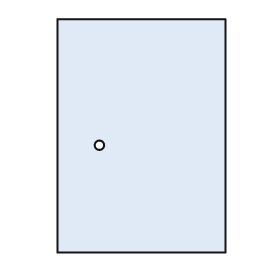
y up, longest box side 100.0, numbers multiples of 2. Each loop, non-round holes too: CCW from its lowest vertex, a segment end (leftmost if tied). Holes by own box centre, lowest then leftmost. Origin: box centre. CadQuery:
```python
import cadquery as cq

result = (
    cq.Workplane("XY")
    .moveTo(-36.0, -50.0)
    .lineTo(36.0, -50.0)
    .lineTo(36.0, 50.0)
    .lineTo(-36.0, 50.0)
    .close()
    .moveTo(-18.0, -4.0)
    .circle(2.0)
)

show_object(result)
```